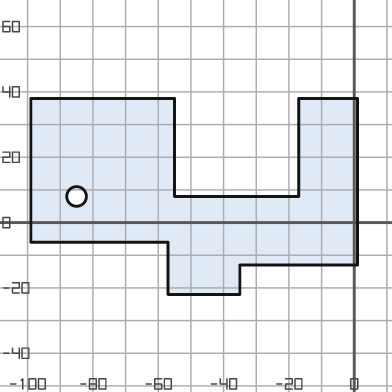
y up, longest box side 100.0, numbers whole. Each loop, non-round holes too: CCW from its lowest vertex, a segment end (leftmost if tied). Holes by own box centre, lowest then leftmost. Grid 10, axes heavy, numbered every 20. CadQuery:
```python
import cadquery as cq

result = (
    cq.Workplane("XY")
    .moveTo(-57.0, -22.0)
    .lineTo(-35.0, -22.0)
    .lineTo(-35.0, -13.0)
    .lineTo(1.0, -13.0)
    .lineTo(1.0, 38.0)
    .lineTo(-17.0, 38.0)
    .lineTo(-17.0, 8.0)
    .lineTo(-55.0, 8.0)
    .lineTo(-55.0, 38.0)
    .lineTo(-99.0, 38.0)
    .lineTo(-99.0, -6.0)
    .lineTo(-57.0, -6.0)
    .close()
    .moveTo(-85.0, 8.0)
    .circle(3.0)
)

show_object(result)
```